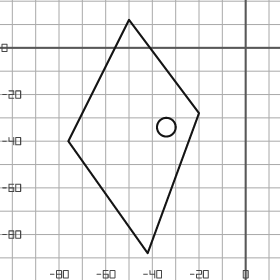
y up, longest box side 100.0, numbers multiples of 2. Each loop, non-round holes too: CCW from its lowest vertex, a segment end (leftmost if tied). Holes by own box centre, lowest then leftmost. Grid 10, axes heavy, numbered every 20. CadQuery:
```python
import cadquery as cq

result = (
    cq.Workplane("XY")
    .moveTo(-42.0, -88.0)
    .lineTo(-20.0, -28.0)
    .lineTo(-50.0, 12.0)
    .lineTo(-76.0, -40.0)
    .close()
    .moveTo(-34.0, -34.0)
    .circle(4.0)
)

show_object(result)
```